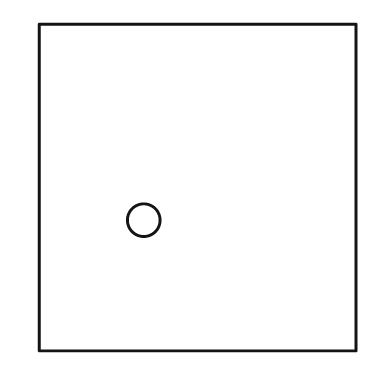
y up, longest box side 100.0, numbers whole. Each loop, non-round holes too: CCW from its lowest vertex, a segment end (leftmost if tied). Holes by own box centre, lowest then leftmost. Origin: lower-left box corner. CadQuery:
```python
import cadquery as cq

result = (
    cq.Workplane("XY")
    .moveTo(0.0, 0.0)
    .lineTo(97.0, 0.0)
    .lineTo(97.0, 100.0)
    .lineTo(0.0, 100.0)
    .close()
    .moveTo(32.0, 40.0)
    .circle(5.0)
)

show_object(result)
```